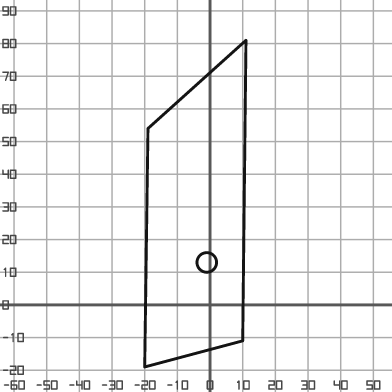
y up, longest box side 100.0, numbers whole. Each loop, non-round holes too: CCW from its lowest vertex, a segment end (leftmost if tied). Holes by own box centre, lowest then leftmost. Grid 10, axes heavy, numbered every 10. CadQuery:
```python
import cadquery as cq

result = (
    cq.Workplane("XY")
    .moveTo(-20.0, -19.0)
    .lineTo(10.0, -11.0)
    .lineTo(11.0, 81.0)
    .lineTo(-19.0, 54.0)
    .close()
    .moveTo(-1.0, 13.0)
    .circle(3.0)
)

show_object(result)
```